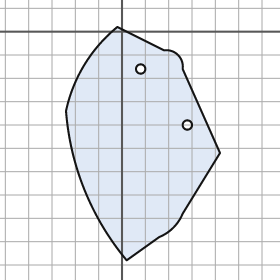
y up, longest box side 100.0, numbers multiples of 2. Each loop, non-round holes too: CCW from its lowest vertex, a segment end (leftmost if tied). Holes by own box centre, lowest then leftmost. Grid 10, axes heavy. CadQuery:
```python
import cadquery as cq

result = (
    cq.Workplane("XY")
    .moveTo(2.0, -98.0)
    .lineTo(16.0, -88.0)
    .threePointArc((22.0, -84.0), (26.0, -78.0))
    .lineTo(42.0, -52.0)
    .lineTo(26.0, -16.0)
    .threePointArc((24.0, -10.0), (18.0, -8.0))
    .lineTo(-2.0, 2.0)
    .threePointArc((-16.0, -14.0), (-24.0, -34.0))
    .threePointArc((-16.0, -68.0), (2.0, -98.0))
    .close()
    .moveTo(28.0, -40.0)
    .circle(2.0)
    .moveTo(8.0, -16.0)
    .circle(2.0)
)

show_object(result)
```